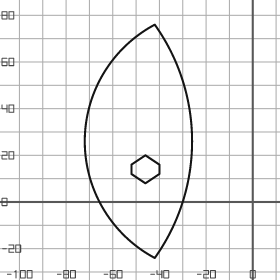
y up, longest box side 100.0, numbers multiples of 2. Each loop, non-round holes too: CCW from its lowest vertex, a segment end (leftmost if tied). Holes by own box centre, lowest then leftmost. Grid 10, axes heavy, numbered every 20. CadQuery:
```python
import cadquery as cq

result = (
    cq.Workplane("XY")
    .moveTo(-42.0, -24.0)
    .threePointArc((-26.0, 26.0), (-42.0, 76.0))
    .threePointArc((-72.0, 26.0), (-42.0, -24.0))
    .close()
    .moveTo(-46.0, 8.0)
    .lineTo(-40.0, 12.0)
    .lineTo(-40.0, 16.0)
    .lineTo(-46.0, 20.0)
    .lineTo(-52.0, 16.0)
    .lineTo(-52.0, 12.0)
    .close()
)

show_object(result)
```